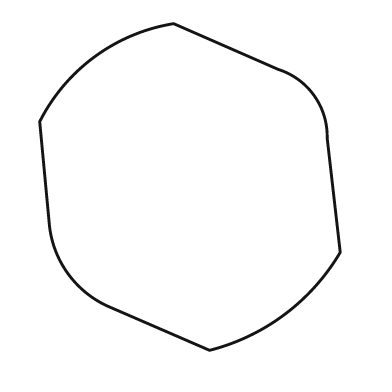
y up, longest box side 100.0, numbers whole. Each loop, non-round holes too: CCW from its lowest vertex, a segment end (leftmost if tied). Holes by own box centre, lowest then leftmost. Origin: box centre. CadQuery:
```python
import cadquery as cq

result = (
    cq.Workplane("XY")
    .moveTo(6.0, -50.0)
    .threePointArc((29.0, -39.0), (46.0, -20.0))
    .lineTo(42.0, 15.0)
    .threePointArc((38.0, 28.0), (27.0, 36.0))
    .lineTo(-5.0, 50.0)
    .threePointArc((-29.0, 40.0), (-46.0, 20.0))
    .lineTo(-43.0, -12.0)
    .threePointArc((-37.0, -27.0), (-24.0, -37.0))
    .close()
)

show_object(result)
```